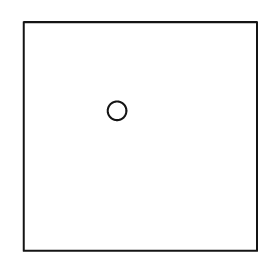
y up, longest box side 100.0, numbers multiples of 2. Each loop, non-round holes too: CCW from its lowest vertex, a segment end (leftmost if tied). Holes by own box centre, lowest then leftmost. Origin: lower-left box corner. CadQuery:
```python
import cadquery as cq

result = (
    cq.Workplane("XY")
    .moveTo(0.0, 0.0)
    .lineTo(100.0, 0.0)
    .lineTo(100.0, 98.0)
    .lineTo(0.0, 98.0)
    .close()
    .moveTo(40.0, 60.0)
    .circle(4.0)
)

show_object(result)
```